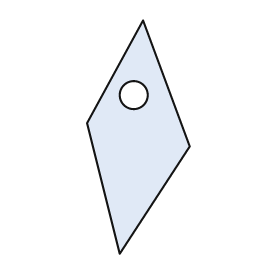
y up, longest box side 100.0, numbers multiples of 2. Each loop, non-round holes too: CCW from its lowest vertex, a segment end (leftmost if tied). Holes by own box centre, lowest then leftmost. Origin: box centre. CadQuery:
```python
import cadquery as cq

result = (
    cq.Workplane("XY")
    .moveTo(-8.0, -50.0)
    .lineTo(22.0, -4.0)
    .lineTo(2.0, 50.0)
    .lineTo(-22.0, 6.0)
    .close()
    .moveTo(-2.0, 18.0)
    .circle(6.0)
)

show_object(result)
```